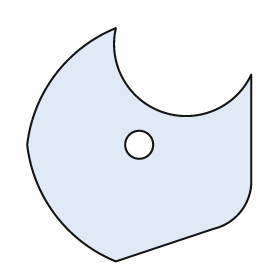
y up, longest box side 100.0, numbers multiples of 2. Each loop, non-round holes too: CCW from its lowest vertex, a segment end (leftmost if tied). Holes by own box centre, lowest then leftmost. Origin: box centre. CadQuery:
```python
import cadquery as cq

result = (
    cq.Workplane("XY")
    .moveTo(-10.0, -50.0)
    .lineTo(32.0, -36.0)
    .threePointArc((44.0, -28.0), (48.0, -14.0))
    .lineTo(48.0, 30.0)
    .threePointArc((10.0, 14.0), (-10.0, 50.0))
    .threePointArc((-36.0, 30.0), (-48.0, 0.0))
    .threePointArc((-36.0, -30.0), (-10.0, -50.0))
    .close()
    .moveTo(0.0, 0.0)
    .circle(6.0)
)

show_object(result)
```